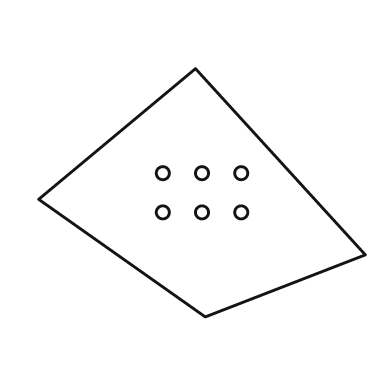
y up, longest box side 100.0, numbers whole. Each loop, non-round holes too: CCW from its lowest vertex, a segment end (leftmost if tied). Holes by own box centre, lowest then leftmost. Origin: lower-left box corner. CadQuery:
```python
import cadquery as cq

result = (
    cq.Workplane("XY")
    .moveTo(51.0, 0.0)
    .lineTo(100.0, 19.0)
    .lineTo(48.0, 76.0)
    .lineTo(0.0, 36.0)
    .close()
    .moveTo(38.0, 32.0)
    .circle(2.0)
    .moveTo(50.0, 32.0)
    .circle(2.0)
    .moveTo(62.0, 32.0)
    .circle(2.0)
    .moveTo(38.0, 44.0)
    .circle(2.0)
    .moveTo(50.0, 44.0)
    .circle(2.0)
    .moveTo(62.0, 44.0)
    .circle(2.0)
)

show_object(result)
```